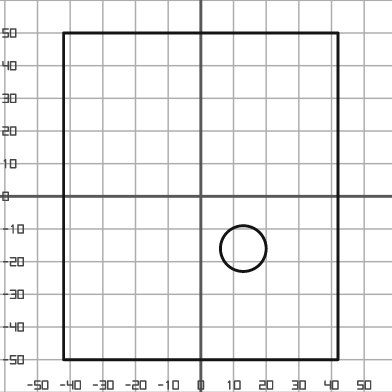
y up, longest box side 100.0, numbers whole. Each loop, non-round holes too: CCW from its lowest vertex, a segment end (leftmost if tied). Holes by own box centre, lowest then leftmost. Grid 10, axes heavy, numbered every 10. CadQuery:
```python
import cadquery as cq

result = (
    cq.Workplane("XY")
    .moveTo(-42.0, -50.0)
    .lineTo(42.0, -50.0)
    .lineTo(42.0, 50.0)
    .lineTo(-42.0, 50.0)
    .close()
    .moveTo(13.0, -16.0)
    .circle(7.0)
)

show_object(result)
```